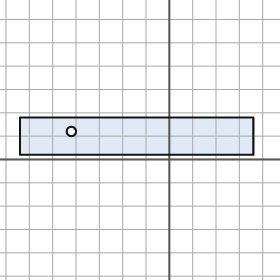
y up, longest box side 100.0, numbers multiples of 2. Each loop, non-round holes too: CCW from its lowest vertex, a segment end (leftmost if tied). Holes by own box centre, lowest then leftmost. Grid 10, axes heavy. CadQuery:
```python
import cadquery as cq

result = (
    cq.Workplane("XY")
    .moveTo(-64.0, 2.0)
    .lineTo(36.0, 2.0)
    .lineTo(36.0, 18.0)
    .lineTo(-64.0, 18.0)
    .close()
    .moveTo(-42.0, 12.0)
    .circle(2.0)
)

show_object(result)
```